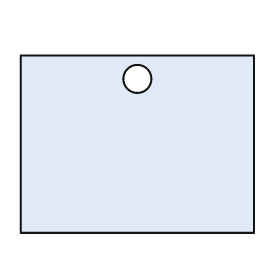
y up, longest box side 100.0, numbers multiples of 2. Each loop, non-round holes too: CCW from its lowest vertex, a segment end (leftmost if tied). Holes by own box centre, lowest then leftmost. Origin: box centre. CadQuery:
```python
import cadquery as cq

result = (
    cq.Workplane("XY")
    .moveTo(-50.0, -38.0)
    .lineTo(50.0, -38.0)
    .lineTo(50.0, 38.0)
    .lineTo(-50.0, 38.0)
    .close()
    .moveTo(0.0, 28.0)
    .circle(6.0)
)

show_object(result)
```